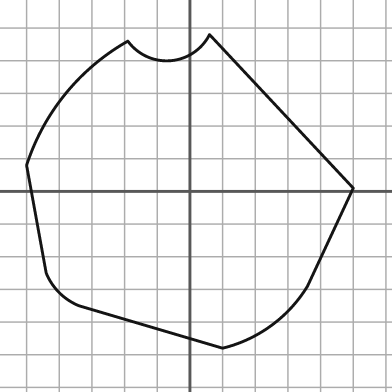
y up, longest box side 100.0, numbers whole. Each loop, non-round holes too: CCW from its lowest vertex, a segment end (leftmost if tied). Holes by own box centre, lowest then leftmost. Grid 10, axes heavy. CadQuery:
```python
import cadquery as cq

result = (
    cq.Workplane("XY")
    .moveTo(10.0, -48.0)
    .threePointArc((25.0, -41.0), (36.0, -29.0))
    .lineTo(50.0, 1.0)
    .lineTo(6.0, 48.0)
    .threePointArc((-6.0, 40.0), (-19.0, 46.0))
    .threePointArc((-38.0, 30.0), (-50.0, 8.0))
    .lineTo(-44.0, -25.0)
    .threePointArc((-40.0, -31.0), (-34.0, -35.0))
    .close()
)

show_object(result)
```